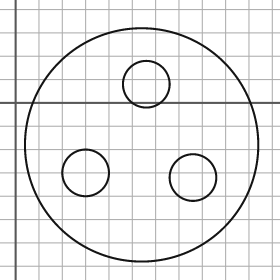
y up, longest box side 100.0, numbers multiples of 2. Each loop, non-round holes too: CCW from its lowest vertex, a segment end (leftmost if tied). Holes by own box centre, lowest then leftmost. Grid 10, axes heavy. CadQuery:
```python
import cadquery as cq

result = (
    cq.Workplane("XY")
    .moveTo(54.0, -18.0)
    .circle(50.0)
    .moveTo(76.0, -32.0)
    .circle(10.0)
    .moveTo(30.0, -30.0)
    .circle(10.0)
    .moveTo(56.0, 8.0)
    .circle(10.0)
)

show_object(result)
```